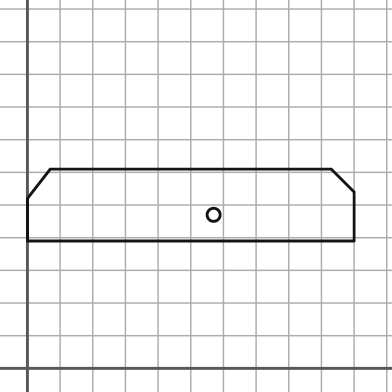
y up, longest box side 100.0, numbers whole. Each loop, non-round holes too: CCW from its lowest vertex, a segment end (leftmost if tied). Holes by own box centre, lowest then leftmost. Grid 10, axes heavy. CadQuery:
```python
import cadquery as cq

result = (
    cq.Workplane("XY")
    .moveTo(0.0, 39.0)
    .lineTo(100.0, 39.0)
    .lineTo(100.0, 54.0)
    .lineTo(93.0, 61.0)
    .lineTo(7.0, 61.0)
    .lineTo(0.0, 52.0)
    .close()
    .moveTo(57.0, 47.0)
    .circle(2.0)
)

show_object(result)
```